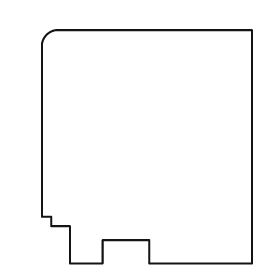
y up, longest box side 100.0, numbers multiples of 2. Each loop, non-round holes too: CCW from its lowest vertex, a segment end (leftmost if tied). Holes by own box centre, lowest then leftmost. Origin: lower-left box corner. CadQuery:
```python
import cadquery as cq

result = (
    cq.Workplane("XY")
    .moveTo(12.0, 0.0)
    .lineTo(26.0, 0.0)
    .lineTo(26.0, 10.0)
    .lineTo(46.0, 10.0)
    .lineTo(46.0, 0.0)
    .lineTo(90.0, 0.0)
    .lineTo(90.0, 100.0)
    .lineTo(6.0, 100.0)
    .threePointArc((2.0, 98.0), (0.0, 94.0))
    .lineTo(0.0, 20.0)
    .lineTo(4.0, 20.0)
    .lineTo(4.0, 16.0)
    .lineTo(12.0, 16.0)
    .close()
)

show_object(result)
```